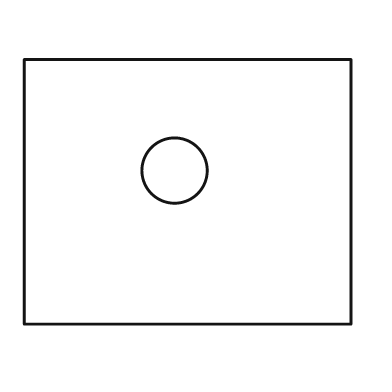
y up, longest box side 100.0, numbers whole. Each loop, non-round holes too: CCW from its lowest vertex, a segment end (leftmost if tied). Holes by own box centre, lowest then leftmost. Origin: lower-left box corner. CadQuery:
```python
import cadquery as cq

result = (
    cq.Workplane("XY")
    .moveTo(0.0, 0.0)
    .lineTo(100.0, 0.0)
    .lineTo(100.0, 81.0)
    .lineTo(0.0, 81.0)
    .close()
    .moveTo(46.0, 47.0)
    .circle(10.0)
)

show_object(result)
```